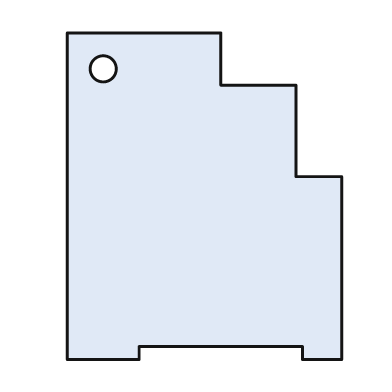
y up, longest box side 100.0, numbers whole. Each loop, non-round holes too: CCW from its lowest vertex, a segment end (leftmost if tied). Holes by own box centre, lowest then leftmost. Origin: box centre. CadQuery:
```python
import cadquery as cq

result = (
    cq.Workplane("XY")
    .moveTo(-42.0, -50.0)
    .lineTo(-20.0, -50.0)
    .lineTo(-20.0, -46.0)
    .lineTo(30.0, -46.0)
    .lineTo(30.0, -50.0)
    .lineTo(42.0, -50.0)
    .lineTo(42.0, 6.0)
    .lineTo(28.0, 6.0)
    .lineTo(28.0, 34.0)
    .lineTo(5.0, 34.0)
    .lineTo(5.0, 50.0)
    .lineTo(-42.0, 50.0)
    .close()
    .moveTo(-31.0, 39.0)
    .circle(4.0)
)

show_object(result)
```